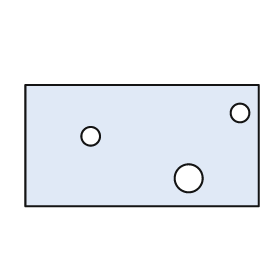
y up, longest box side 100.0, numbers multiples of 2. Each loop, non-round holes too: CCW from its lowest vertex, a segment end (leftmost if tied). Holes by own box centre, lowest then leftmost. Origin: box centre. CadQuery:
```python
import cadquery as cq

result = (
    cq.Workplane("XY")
    .moveTo(-50.0, -26.0)
    .lineTo(50.0, -26.0)
    .lineTo(50.0, 26.0)
    .lineTo(-50.0, 26.0)
    .close()
    .moveTo(20.0, -14.0)
    .circle(6.0)
    .moveTo(-22.0, 4.0)
    .circle(4.0)
    .moveTo(42.0, 14.0)
    .circle(4.0)
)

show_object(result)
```